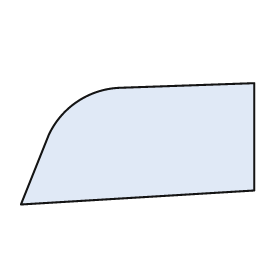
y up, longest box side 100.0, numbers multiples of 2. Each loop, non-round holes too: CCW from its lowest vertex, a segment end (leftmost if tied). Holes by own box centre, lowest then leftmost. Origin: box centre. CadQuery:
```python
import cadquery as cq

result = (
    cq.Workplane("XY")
    .moveTo(-50.0, -26.0)
    .lineTo(50.0, -20.0)
    .lineTo(50.0, 26.0)
    .lineTo(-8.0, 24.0)
    .threePointArc((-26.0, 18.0), (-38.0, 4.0))
    .close()
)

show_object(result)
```